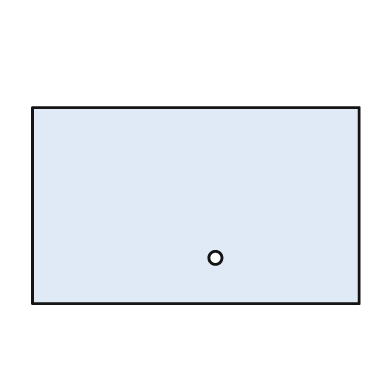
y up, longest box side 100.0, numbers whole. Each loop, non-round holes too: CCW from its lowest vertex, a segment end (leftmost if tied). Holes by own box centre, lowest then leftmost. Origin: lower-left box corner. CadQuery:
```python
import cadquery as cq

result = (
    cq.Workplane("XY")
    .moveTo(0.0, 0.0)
    .lineTo(100.0, 0.0)
    .lineTo(100.0, 60.0)
    .lineTo(0.0, 60.0)
    .close()
    .moveTo(56.0, 14.0)
    .circle(2.0)
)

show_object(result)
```